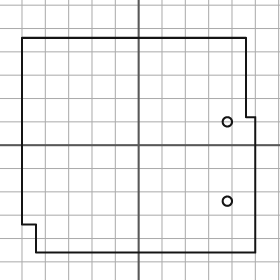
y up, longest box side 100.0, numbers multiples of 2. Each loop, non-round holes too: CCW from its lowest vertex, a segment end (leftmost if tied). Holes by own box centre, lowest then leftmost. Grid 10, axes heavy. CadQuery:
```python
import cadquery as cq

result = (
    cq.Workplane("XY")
    .moveTo(-44.0, -46.0)
    .lineTo(50.0, -46.0)
    .lineTo(50.0, 12.0)
    .lineTo(46.0, 12.0)
    .lineTo(46.0, 46.0)
    .lineTo(-50.0, 46.0)
    .lineTo(-50.0, -34.0)
    .lineTo(-44.0, -34.0)
    .close()
    .moveTo(38.0, -24.0)
    .circle(2.0)
    .moveTo(38.0, 10.0)
    .circle(2.0)
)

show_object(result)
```